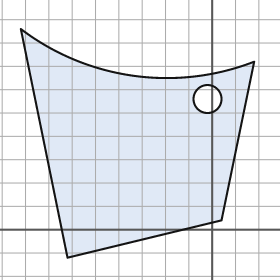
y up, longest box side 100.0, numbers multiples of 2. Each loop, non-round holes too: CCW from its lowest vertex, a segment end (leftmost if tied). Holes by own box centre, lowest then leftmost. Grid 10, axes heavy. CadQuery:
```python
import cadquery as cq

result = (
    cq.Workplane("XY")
    .moveTo(-62.0, -12.0)
    .lineTo(4.0, 4.0)
    .lineTo(18.0, 72.0)
    .threePointArc((-34.0, 66.0), (-82.0, 86.0))
    .close()
    .moveTo(-2.0, 56.0)
    .circle(6.0)
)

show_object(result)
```